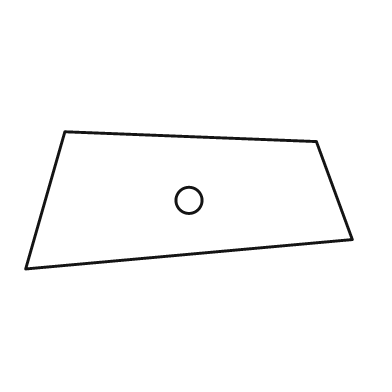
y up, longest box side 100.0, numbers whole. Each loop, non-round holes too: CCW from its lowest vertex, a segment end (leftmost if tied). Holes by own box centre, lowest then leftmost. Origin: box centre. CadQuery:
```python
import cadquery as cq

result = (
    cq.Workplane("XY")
    .moveTo(-50.0, -21.0)
    .lineTo(50.0, -12.0)
    .lineTo(39.0, 18.0)
    .lineTo(-38.0, 21.0)
    .close()
    .moveTo(0.0, 0.0)
    .circle(4.0)
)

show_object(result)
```